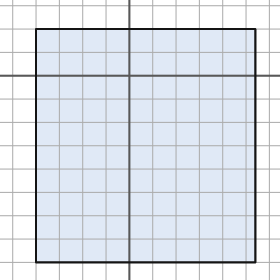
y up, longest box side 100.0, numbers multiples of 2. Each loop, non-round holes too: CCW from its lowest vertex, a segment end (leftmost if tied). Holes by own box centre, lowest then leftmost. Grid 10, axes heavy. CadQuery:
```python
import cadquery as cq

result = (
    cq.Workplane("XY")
    .moveTo(-40.0, -80.0)
    .lineTo(54.0, -80.0)
    .lineTo(54.0, 20.0)
    .lineTo(-40.0, 20.0)
    .close()
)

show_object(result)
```